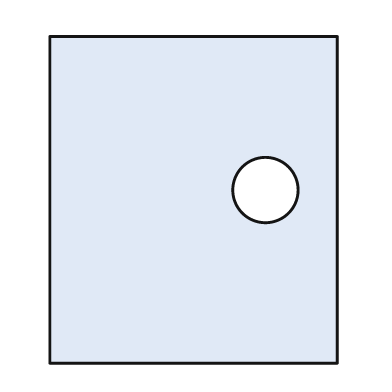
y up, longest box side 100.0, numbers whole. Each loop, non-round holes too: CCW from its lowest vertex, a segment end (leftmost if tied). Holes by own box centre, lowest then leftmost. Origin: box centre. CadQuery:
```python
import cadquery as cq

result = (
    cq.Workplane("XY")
    .moveTo(-44.0, -50.0)
    .lineTo(44.0, -50.0)
    .lineTo(44.0, 50.0)
    .lineTo(-44.0, 50.0)
    .close()
    .moveTo(22.0, 3.0)
    .circle(10.0)
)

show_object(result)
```